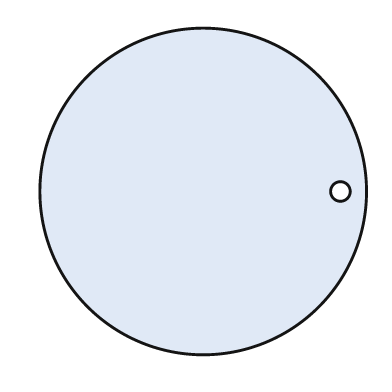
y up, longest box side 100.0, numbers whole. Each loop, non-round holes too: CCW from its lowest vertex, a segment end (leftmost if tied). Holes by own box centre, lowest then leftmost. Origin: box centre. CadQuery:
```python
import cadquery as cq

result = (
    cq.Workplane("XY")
    .moveTo(0.0, 0.0)
    .circle(50.0)
    .moveTo(42.0, 0.0)
    .circle(3.0)
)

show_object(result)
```